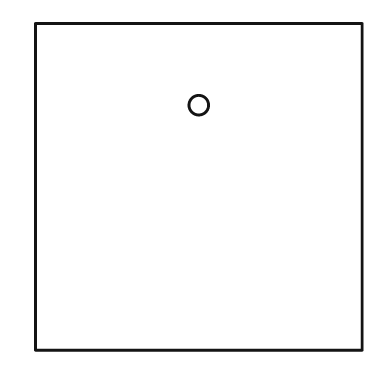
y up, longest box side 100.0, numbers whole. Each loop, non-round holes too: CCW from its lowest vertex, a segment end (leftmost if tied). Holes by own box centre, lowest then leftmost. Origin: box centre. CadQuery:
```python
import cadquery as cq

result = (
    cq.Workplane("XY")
    .moveTo(-50.0, -50.0)
    .lineTo(50.0, -50.0)
    .lineTo(50.0, 50.0)
    .lineTo(-50.0, 50.0)
    .close()
    .moveTo(0.0, 25.0)
    .circle(3.0)
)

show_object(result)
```